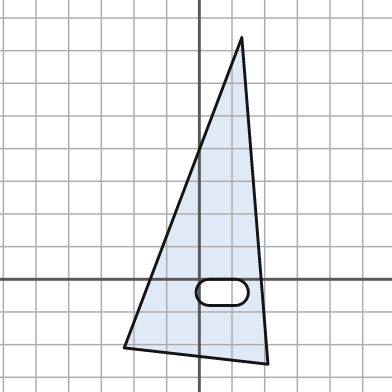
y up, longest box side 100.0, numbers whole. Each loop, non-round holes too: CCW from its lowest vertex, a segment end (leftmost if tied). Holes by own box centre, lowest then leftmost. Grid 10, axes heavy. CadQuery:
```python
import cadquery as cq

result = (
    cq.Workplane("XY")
    .moveTo(21.0, -26.0)
    .lineTo(13.0, 74.0)
    .lineTo(-23.0, -21.0)
    .close()
    .moveTo(3.0, -8.0)
    .lineTo(11.0, -8.0)
    .threePointArc((15.0, -4.0), (11.0, 0.0))
    .lineTo(3.0, 0.0)
    .threePointArc((-1.0, -4.0), (3.0, -8.0))
    .close()
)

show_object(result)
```